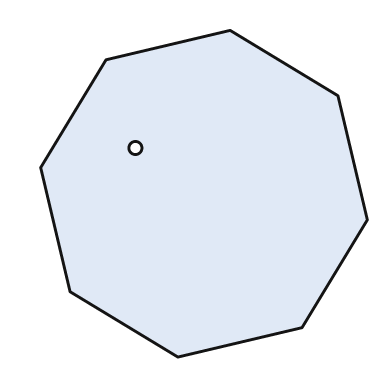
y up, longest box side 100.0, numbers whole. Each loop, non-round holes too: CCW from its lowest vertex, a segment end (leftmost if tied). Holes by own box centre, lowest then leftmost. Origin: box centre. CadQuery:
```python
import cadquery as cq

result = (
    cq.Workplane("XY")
    .moveTo(-8.0, -50.0)
    .lineTo(30.0, -41.0)
    .lineTo(50.0, -8.0)
    .lineTo(41.0, 30.0)
    .lineTo(8.0, 50.0)
    .lineTo(-30.0, 41.0)
    .lineTo(-50.0, 8.0)
    .lineTo(-41.0, -30.0)
    .close()
    .moveTo(-21.0, 14.0)
    .circle(2.0)
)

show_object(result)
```